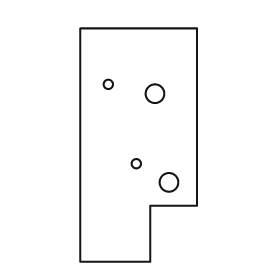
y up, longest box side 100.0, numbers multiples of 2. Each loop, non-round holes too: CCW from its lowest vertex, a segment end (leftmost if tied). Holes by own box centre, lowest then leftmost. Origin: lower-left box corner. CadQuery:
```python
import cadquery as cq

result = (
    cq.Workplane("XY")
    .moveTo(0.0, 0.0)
    .lineTo(30.0, 0.0)
    .lineTo(30.0, 24.0)
    .lineTo(50.0, 24.0)
    .lineTo(50.0, 100.0)
    .lineTo(0.0, 100.0)
    .close()
    .moveTo(38.0, 34.0)
    .circle(4.0)
    .moveTo(24.0, 42.0)
    .circle(2.0)
    .moveTo(32.0, 72.0)
    .circle(4.0)
    .moveTo(12.0, 76.0)
    .circle(2.0)
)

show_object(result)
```